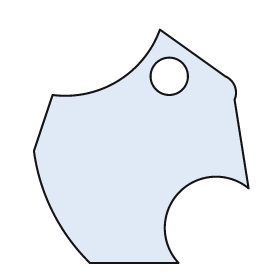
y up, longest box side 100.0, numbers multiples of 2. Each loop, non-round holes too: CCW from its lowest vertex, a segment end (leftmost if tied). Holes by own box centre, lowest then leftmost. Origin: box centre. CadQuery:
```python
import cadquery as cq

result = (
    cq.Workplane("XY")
    .moveTo(-22.0, -50.0)
    .lineTo(16.0, -50.0)
    .threePointArc((16.0, -20.0), (46.0, -18.0))
    .lineTo(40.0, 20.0)
    .threePointArc((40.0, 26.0), (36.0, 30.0))
    .lineTo(8.0, 50.0)
    .threePointArc((-10.0, 28.0), (-38.0, 22.0))
    .lineTo(-46.0, -2.0)
    .threePointArc((-38.0, -28.0), (-22.0, -50.0))
    .close()
    .moveTo(12.0, 30.0)
    .circle(8.0)
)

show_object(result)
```